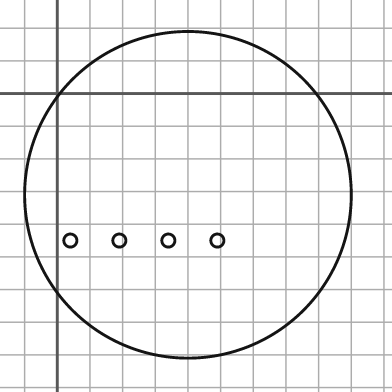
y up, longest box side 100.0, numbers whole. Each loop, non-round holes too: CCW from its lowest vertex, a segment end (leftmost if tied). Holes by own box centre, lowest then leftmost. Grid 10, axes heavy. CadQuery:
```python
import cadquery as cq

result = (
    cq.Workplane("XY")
    .moveTo(40.0, -31.0)
    .circle(50.0)
    .moveTo(4.0, -45.0)
    .circle(2.0)
    .moveTo(19.0, -45.0)
    .circle(2.0)
    .moveTo(34.0, -45.0)
    .circle(2.0)
    .moveTo(49.0, -45.0)
    .circle(2.0)
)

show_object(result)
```